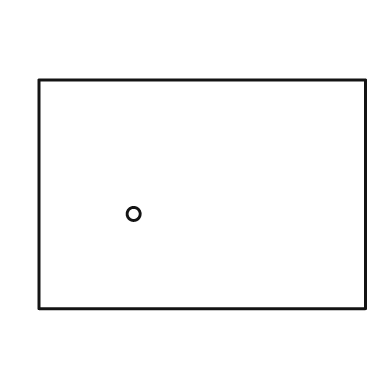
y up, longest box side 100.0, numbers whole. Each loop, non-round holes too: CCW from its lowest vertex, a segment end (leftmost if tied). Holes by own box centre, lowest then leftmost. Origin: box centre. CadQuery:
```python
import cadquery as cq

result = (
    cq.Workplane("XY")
    .moveTo(-50.0, -35.0)
    .lineTo(50.0, -35.0)
    .lineTo(50.0, 35.0)
    .lineTo(-50.0, 35.0)
    .close()
    .moveTo(-21.0, -6.0)
    .circle(2.0)
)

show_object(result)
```